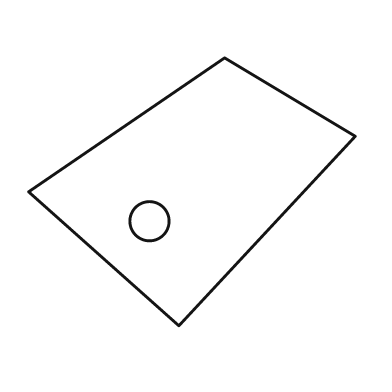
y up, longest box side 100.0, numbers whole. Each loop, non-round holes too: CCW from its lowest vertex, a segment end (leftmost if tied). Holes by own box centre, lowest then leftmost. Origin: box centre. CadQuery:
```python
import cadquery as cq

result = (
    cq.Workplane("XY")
    .moveTo(-4.0, -41.0)
    .lineTo(50.0, 17.0)
    .lineTo(10.0, 41.0)
    .lineTo(-50.0, 0.0)
    .close()
    .moveTo(-13.0, -9.0)
    .circle(6.0)
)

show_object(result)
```